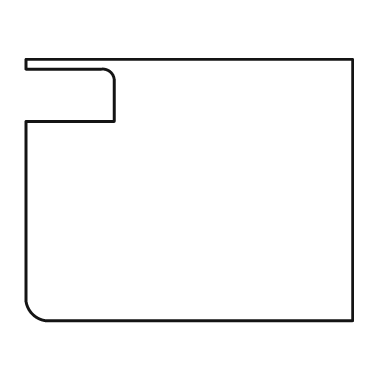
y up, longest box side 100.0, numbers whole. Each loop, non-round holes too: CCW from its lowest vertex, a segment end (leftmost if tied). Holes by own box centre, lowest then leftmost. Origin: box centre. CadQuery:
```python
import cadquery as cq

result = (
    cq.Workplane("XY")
    .moveTo(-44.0, -40.0)
    .lineTo(50.0, -40.0)
    .lineTo(50.0, 40.0)
    .lineTo(-50.0, 40.0)
    .lineTo(-50.0, 37.0)
    .lineTo(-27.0, 37.0)
    .threePointArc((-24.0, 36.0), (-23.0, 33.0))
    .lineTo(-23.0, 21.0)
    .lineTo(-50.0, 21.0)
    .lineTo(-50.0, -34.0)
    .threePointArc((-48.0, -38.0), (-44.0, -40.0))
    .close()
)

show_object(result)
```